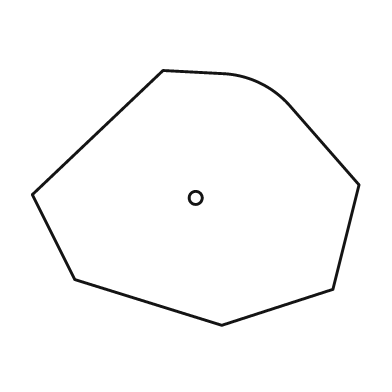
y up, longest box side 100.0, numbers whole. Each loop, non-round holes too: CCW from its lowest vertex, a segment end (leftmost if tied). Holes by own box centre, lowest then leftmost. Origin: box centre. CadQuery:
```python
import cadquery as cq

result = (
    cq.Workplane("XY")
    .moveTo(8.0, -39.0)
    .lineTo(42.0, -28.0)
    .lineTo(50.0, 4.0)
    .lineTo(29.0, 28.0)
    .threePointArc((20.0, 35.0), (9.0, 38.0))
    .lineTo(-10.0, 39.0)
    .lineTo(-50.0, 1.0)
    .lineTo(-37.0, -25.0)
    .close()
    .moveTo(0.0, 0.0)
    .circle(2.0)
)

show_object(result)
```